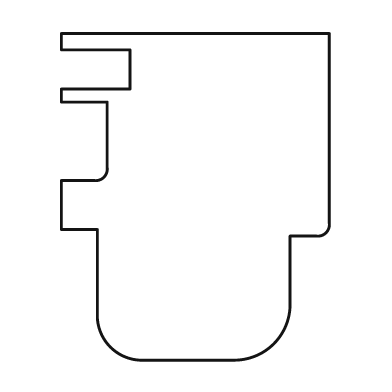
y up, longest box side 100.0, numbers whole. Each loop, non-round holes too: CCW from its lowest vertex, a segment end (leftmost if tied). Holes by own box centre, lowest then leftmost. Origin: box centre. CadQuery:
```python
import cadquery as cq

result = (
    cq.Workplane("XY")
    .moveTo(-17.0, -50.0)
    .lineTo(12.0, -50.0)
    .threePointArc((24.0, -45.0), (29.0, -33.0))
    .lineTo(29.0, -12.0)
    .lineTo(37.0, -12.0)
    .threePointArc((40.0, -11.0), (41.0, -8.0))
    .lineTo(41.0, 50.0)
    .lineTo(-41.0, 50.0)
    .lineTo(-41.0, 45.0)
    .lineTo(-20.0, 45.0)
    .lineTo(-20.0, 33.0)
    .lineTo(-41.0, 33.0)
    .lineTo(-41.0, 29.0)
    .lineTo(-27.0, 29.0)
    .lineTo(-27.0, 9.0)
    .threePointArc((-28.0, 6.0), (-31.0, 5.0))
    .lineTo(-41.0, 5.0)
    .lineTo(-41.0, -10.0)
    .lineTo(-30.0, -10.0)
    .lineTo(-30.0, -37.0)
    .threePointArc((-26.0, -46.0), (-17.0, -50.0))
    .close()
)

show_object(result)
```